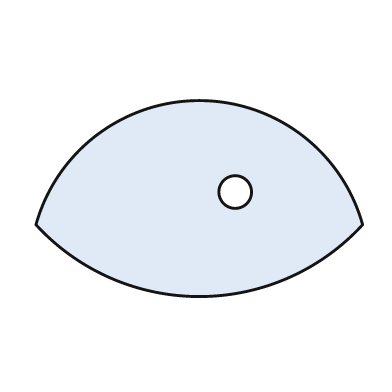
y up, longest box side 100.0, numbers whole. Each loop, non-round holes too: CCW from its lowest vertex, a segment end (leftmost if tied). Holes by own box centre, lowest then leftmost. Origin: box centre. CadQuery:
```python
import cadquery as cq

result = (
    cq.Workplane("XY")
    .moveTo(-50.0, -8.0)
    .threePointArc((0.0, -30.0), (50.0, -8.0))
    .threePointArc((0.0, 30.0), (-50.0, -8.0))
    .close()
    .moveTo(11.0, 2.0)
    .circle(5.0)
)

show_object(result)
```